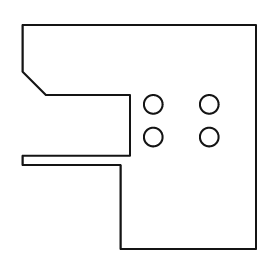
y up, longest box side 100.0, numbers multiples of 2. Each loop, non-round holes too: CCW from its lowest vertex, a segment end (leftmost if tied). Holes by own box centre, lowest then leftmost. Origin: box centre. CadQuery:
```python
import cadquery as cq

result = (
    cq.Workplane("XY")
    .moveTo(-8.0, -48.0)
    .lineTo(50.0, -48.0)
    .lineTo(50.0, 48.0)
    .lineTo(-50.0, 48.0)
    .lineTo(-50.0, 28.0)
    .lineTo(-40.0, 18.0)
    .lineTo(-4.0, 18.0)
    .lineTo(-4.0, -8.0)
    .lineTo(-50.0, -8.0)
    .lineTo(-50.0, -12.0)
    .lineTo(-8.0, -12.0)
    .close()
    .moveTo(6.0, 0.0)
    .circle(4.0)
    .moveTo(30.0, 0.0)
    .circle(4.0)
    .moveTo(6.0, 14.0)
    .circle(4.0)
    .moveTo(30.0, 14.0)
    .circle(4.0)
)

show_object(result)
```